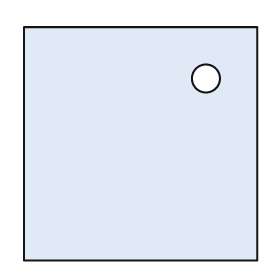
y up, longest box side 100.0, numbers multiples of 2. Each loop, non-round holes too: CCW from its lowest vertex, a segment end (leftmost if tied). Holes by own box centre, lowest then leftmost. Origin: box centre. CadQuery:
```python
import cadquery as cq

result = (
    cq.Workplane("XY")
    .moveTo(-50.0, -50.0)
    .lineTo(50.0, -50.0)
    .lineTo(50.0, 50.0)
    .lineTo(-50.0, 50.0)
    .close()
    .moveTo(28.0, 28.0)
    .circle(6.0)
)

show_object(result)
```